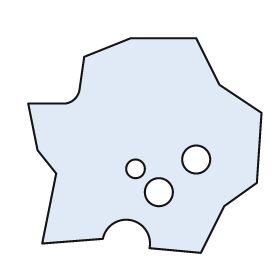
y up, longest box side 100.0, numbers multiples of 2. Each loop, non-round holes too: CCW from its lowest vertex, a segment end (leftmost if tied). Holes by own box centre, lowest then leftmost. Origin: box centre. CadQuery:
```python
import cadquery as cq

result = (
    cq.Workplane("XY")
    .moveTo(24.0, -46.0)
    .lineTo(34.0, -26.0)
    .lineTo(48.0, -16.0)
    .lineTo(50.0, 14.0)
    .lineTo(32.0, 26.0)
    .lineTo(22.0, 46.0)
    .lineTo(-6.0, 46.0)
    .lineTo(-26.0, 38.0)
    .lineTo(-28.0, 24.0)
    .threePointArc((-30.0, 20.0), (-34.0, 18.0))
    .lineTo(-50.0, 18.0)
    .lineTo(-46.0, -2.0)
    .lineTo(-38.0, -12.0)
    .lineTo(-44.0, -42.0)
    .lineTo(-18.0, -40.0)
    .threePointArc((-6.0, -32.0), (2.0, -44.0))
    .close()
    .moveTo(6.0, -20.0)
    .circle(6.0)
    .moveTo(-4.0, -10.0)
    .circle(4.0)
    .moveTo(22.0, -6.0)
    .circle(6.0)
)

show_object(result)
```